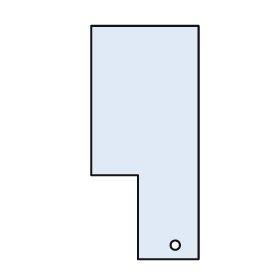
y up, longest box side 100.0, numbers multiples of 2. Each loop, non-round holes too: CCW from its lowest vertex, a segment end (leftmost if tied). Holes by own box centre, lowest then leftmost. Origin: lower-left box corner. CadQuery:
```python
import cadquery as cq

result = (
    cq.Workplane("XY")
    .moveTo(20.0, 0.0)
    .lineTo(46.0, 0.0)
    .lineTo(46.0, 100.0)
    .lineTo(0.0, 100.0)
    .lineTo(0.0, 36.0)
    .lineTo(20.0, 36.0)
    .close()
    .moveTo(36.0, 6.0)
    .circle(2.0)
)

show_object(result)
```